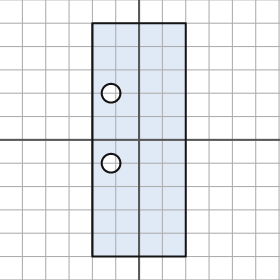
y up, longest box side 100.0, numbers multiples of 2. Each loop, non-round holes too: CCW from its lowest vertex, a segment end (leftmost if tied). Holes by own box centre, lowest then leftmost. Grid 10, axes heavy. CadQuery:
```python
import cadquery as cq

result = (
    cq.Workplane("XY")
    .moveTo(-20.0, -50.0)
    .lineTo(20.0, -50.0)
    .lineTo(20.0, 50.0)
    .lineTo(-20.0, 50.0)
    .close()
    .moveTo(-12.0, -10.0)
    .circle(4.0)
    .moveTo(-12.0, 20.0)
    .circle(4.0)
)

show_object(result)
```